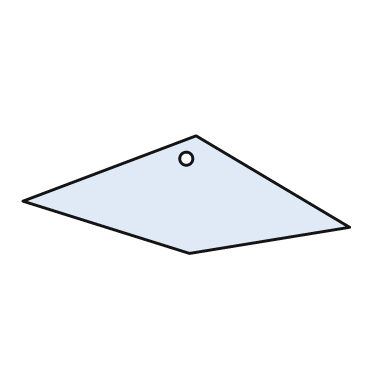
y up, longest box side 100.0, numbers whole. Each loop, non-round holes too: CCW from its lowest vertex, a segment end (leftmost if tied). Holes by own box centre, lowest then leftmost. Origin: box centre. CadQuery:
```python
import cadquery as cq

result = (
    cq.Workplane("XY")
    .moveTo(1.0, -18.0)
    .lineTo(50.0, -10.0)
    .lineTo(3.0, 18.0)
    .lineTo(-50.0, -2.0)
    .close()
    .moveTo(0.0, 11.0)
    .circle(2.0)
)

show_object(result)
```